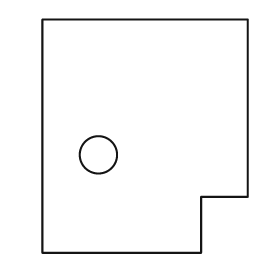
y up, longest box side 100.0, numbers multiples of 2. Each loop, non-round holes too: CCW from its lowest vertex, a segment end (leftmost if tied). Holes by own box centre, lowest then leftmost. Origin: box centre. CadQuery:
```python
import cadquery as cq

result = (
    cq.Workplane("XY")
    .moveTo(-44.0, -50.0)
    .lineTo(24.0, -50.0)
    .lineTo(24.0, -26.0)
    .lineTo(44.0, -26.0)
    .lineTo(44.0, 50.0)
    .lineTo(-44.0, 50.0)
    .close()
    .moveTo(-20.0, -8.0)
    .circle(8.0)
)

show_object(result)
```